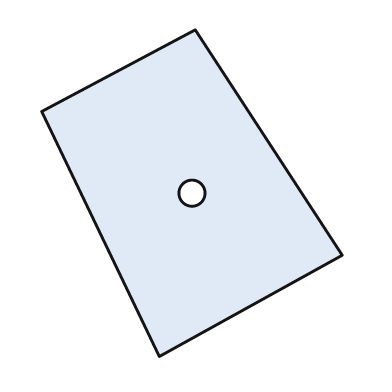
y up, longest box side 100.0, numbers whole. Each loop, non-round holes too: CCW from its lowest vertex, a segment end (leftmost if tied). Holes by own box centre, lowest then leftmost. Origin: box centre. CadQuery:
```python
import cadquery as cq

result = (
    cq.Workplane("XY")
    .moveTo(-10.0, -50.0)
    .lineTo(46.0, -19.0)
    .lineTo(1.0, 50.0)
    .lineTo(-46.0, 25.0)
    .close()
    .moveTo(0.0, 0.0)
    .circle(4.0)
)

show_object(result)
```